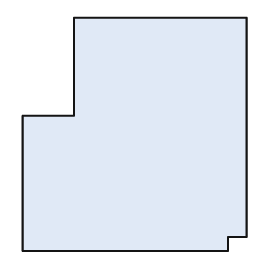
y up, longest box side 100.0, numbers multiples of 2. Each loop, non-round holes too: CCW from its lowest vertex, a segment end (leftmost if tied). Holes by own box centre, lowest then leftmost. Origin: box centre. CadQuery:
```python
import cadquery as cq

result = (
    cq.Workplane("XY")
    .moveTo(-48.0, -50.0)
    .lineTo(40.0, -50.0)
    .lineTo(40.0, -44.0)
    .lineTo(48.0, -44.0)
    .lineTo(48.0, 50.0)
    .lineTo(-26.0, 50.0)
    .lineTo(-26.0, 8.0)
    .lineTo(-48.0, 8.0)
    .close()
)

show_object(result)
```